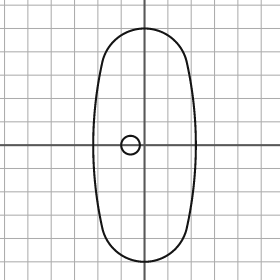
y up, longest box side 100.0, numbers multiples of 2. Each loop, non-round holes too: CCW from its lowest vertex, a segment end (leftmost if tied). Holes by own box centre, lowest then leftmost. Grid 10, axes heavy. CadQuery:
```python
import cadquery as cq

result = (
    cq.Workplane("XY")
    .moveTo(-18.0, -36.0)
    .threePointArc((0.0, -50.0), (18.0, -36.0))
    .threePointArc((22.0, 0.0), (18.0, 36.0))
    .threePointArc((0.0, 50.0), (-18.0, 36.0))
    .threePointArc((-22.0, 0.0), (-18.0, -36.0))
    .close()
    .moveTo(-6.0, 0.0)
    .circle(4.0)
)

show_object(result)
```